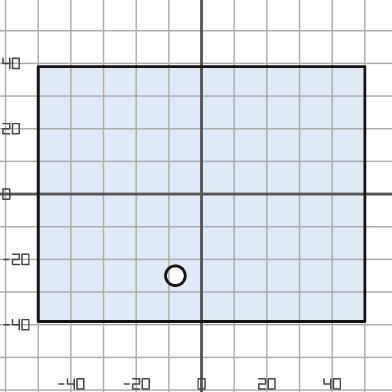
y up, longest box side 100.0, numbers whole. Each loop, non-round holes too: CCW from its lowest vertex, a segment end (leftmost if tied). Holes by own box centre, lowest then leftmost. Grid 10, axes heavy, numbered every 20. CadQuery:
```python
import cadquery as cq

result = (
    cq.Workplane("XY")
    .moveTo(-50.0, -39.0)
    .lineTo(50.0, -39.0)
    .lineTo(50.0, 39.0)
    .lineTo(-50.0, 39.0)
    .close()
    .moveTo(-8.0, -25.0)
    .circle(3.0)
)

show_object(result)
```